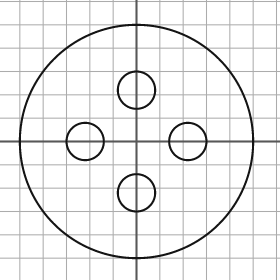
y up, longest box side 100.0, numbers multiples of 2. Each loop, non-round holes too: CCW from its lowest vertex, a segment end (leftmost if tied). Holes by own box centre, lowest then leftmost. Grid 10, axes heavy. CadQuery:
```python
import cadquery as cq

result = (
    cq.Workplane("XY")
    .moveTo(0.0, 0.0)
    .circle(50.0)
    .moveTo(0.0, -22.0)
    .circle(8.0)
    .moveTo(-22.0, 0.0)
    .circle(8.0)
    .moveTo(22.0, 0.0)
    .circle(8.0)
    .moveTo(0.0, 22.0)
    .circle(8.0)
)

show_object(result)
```